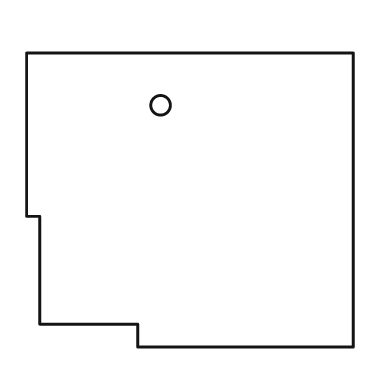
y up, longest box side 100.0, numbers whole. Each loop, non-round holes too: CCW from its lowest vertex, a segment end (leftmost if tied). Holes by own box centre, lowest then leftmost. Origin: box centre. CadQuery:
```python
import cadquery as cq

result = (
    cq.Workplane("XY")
    .moveTo(-16.0, -45.0)
    .lineTo(50.0, -45.0)
    .lineTo(50.0, 45.0)
    .lineTo(-50.0, 45.0)
    .lineTo(-50.0, -5.0)
    .lineTo(-46.0, -5.0)
    .lineTo(-46.0, -38.0)
    .lineTo(-16.0, -38.0)
    .close()
    .moveTo(-9.0, 29.0)
    .circle(3.0)
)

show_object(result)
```